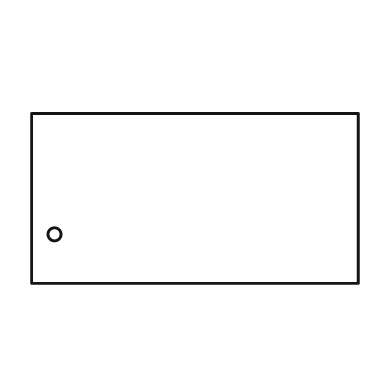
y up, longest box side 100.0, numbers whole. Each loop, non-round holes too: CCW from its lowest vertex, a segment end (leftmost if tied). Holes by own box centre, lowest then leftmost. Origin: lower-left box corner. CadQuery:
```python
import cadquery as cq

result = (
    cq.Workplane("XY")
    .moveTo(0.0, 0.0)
    .lineTo(100.0, 0.0)
    .lineTo(100.0, 52.0)
    .lineTo(0.0, 52.0)
    .close()
    .moveTo(7.0, 15.0)
    .circle(2.0)
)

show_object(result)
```